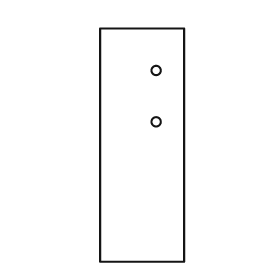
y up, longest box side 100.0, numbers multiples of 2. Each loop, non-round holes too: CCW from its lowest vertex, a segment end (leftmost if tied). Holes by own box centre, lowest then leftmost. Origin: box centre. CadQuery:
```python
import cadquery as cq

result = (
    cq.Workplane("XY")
    .moveTo(-18.0, -50.0)
    .lineTo(18.0, -50.0)
    .lineTo(18.0, 50.0)
    .lineTo(-18.0, 50.0)
    .close()
    .moveTo(6.0, 10.0)
    .circle(2.0)
    .moveTo(6.0, 32.0)
    .circle(2.0)
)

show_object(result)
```